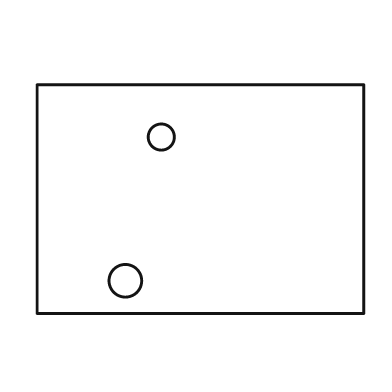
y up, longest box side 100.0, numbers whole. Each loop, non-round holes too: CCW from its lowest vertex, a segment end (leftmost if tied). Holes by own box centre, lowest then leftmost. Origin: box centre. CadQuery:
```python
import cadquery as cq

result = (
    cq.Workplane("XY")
    .moveTo(-50.0, -35.0)
    .lineTo(50.0, -35.0)
    .lineTo(50.0, 35.0)
    .lineTo(-50.0, 35.0)
    .close()
    .moveTo(-23.0, -25.0)
    .circle(5.0)
    .moveTo(-12.0, 19.0)
    .circle(4.0)
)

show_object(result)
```